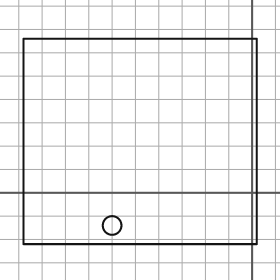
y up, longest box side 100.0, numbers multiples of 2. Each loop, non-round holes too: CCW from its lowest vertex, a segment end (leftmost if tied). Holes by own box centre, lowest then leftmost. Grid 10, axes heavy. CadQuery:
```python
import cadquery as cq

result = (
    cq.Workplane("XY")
    .moveTo(-98.0, -22.0)
    .lineTo(2.0, -22.0)
    .lineTo(2.0, 66.0)
    .lineTo(-98.0, 66.0)
    .close()
    .moveTo(-60.0, -14.0)
    .circle(4.0)
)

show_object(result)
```